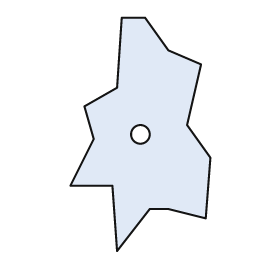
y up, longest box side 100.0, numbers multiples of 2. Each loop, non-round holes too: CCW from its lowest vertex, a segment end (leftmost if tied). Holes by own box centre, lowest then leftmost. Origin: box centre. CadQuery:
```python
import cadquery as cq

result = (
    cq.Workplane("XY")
    .moveTo(-10.0, -50.0)
    .lineTo(4.0, -32.0)
    .lineTo(12.0, -32.0)
    .lineTo(28.0, -36.0)
    .lineTo(30.0, -10.0)
    .lineTo(20.0, 4.0)
    .lineTo(26.0, 30.0)
    .lineTo(12.0, 36.0)
    .lineTo(2.0, 50.0)
    .lineTo(-8.0, 50.0)
    .lineTo(-10.0, 20.0)
    .lineTo(-24.0, 12.0)
    .lineTo(-20.0, -2.0)
    .lineTo(-30.0, -22.0)
    .lineTo(-12.0, -22.0)
    .close()
    .moveTo(0.0, 0.0)
    .circle(4.0)
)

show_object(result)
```